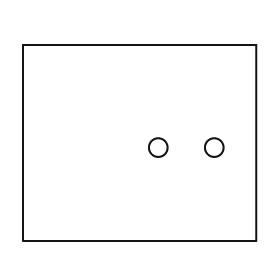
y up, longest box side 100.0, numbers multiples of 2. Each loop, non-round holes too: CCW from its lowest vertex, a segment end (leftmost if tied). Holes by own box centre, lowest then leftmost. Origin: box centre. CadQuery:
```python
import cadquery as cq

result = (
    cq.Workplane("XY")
    .moveTo(-50.0, -42.0)
    .lineTo(50.0, -42.0)
    .lineTo(50.0, 42.0)
    .lineTo(-50.0, 42.0)
    .close()
    .moveTo(8.0, -2.0)
    .circle(4.0)
    .moveTo(32.0, -2.0)
    .circle(4.0)
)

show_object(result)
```